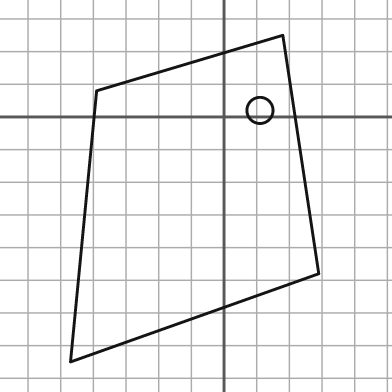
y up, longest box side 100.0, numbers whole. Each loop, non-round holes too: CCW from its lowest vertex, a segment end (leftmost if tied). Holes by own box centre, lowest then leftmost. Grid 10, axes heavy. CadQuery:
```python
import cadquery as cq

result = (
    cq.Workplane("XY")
    .moveTo(-47.0, -75.0)
    .lineTo(29.0, -48.0)
    .lineTo(18.0, 25.0)
    .lineTo(-39.0, 8.0)
    .close()
    .moveTo(11.0, 2.0)
    .circle(4.0)
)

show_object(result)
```